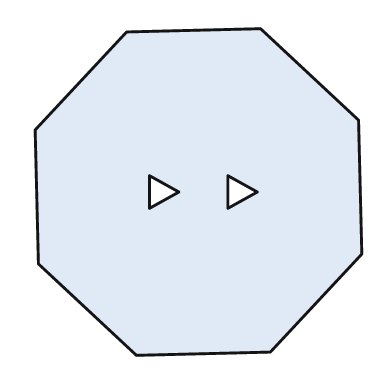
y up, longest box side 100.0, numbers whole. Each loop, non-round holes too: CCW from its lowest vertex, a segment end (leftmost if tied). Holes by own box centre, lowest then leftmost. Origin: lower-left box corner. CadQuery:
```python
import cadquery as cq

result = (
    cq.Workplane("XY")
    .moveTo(31.0, 0.0)
    .lineTo(72.0, 1.0)
    .lineTo(100.0, 31.0)
    .lineTo(99.0, 72.0)
    .lineTo(69.0, 100.0)
    .lineTo(28.0, 99.0)
    .lineTo(0.0, 69.0)
    .lineTo(1.0, 28.0)
    .close()
    .moveTo(35.0, 45.0)
    .lineTo(44.0, 50.0)
    .lineTo(35.0, 55.0)
    .close()
    .moveTo(59.0, 45.0)
    .lineTo(68.0, 50.0)
    .lineTo(59.0, 55.0)
    .close()
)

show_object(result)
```